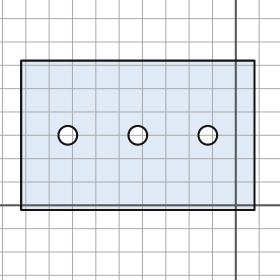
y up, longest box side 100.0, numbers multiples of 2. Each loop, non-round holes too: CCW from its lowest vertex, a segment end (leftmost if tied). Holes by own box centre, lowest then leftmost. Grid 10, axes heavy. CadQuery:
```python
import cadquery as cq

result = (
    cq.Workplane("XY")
    .moveTo(-92.0, -2.0)
    .lineTo(8.0, -2.0)
    .lineTo(8.0, 62.0)
    .lineTo(-92.0, 62.0)
    .close()
    .moveTo(-72.0, 30.0)
    .circle(4.0)
    .moveTo(-42.0, 30.0)
    .circle(4.0)
    .moveTo(-12.0, 30.0)
    .circle(4.0)
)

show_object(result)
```